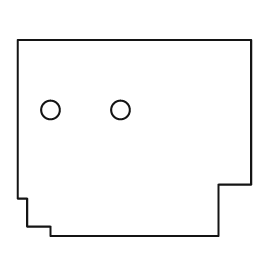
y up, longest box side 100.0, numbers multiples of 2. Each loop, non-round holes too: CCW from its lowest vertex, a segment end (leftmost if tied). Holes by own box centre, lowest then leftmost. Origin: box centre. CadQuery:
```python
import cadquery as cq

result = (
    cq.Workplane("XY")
    .moveTo(-36.0, -42.0)
    .lineTo(36.0, -42.0)
    .lineTo(36.0, -20.0)
    .lineTo(50.0, -20.0)
    .lineTo(50.0, 42.0)
    .lineTo(-50.0, 42.0)
    .lineTo(-50.0, -26.0)
    .lineTo(-46.0, -26.0)
    .lineTo(-46.0, -38.0)
    .lineTo(-36.0, -38.0)
    .close()
    .moveTo(-36.0, 12.0)
    .circle(4.0)
    .moveTo(-6.0, 12.0)
    .circle(4.0)
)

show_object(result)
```